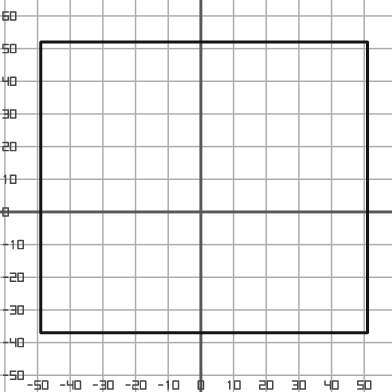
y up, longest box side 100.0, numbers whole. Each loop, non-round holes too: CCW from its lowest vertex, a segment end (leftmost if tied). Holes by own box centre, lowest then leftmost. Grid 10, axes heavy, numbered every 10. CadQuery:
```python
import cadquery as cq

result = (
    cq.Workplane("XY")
    .moveTo(-49.0, -37.0)
    .lineTo(51.0, -37.0)
    .lineTo(51.0, 52.0)
    .lineTo(-49.0, 52.0)
    .close()
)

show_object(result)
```